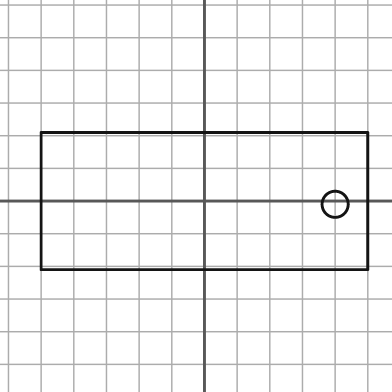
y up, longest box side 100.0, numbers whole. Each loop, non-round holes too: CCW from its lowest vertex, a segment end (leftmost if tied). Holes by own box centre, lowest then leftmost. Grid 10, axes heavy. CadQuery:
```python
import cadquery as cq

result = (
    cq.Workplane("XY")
    .moveTo(-50.0, -21.0)
    .lineTo(50.0, -21.0)
    .lineTo(50.0, 21.0)
    .lineTo(-50.0, 21.0)
    .close()
    .moveTo(40.0, -1.0)
    .circle(4.0)
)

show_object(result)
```